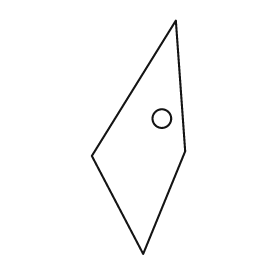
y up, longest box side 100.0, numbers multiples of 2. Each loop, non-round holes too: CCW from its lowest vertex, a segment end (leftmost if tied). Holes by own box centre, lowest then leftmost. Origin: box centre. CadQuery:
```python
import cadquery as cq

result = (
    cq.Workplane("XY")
    .moveTo(2.0, -50.0)
    .lineTo(20.0, -6.0)
    .lineTo(16.0, 50.0)
    .lineTo(-20.0, -8.0)
    .close()
    .moveTo(10.0, 8.0)
    .circle(4.0)
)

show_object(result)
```